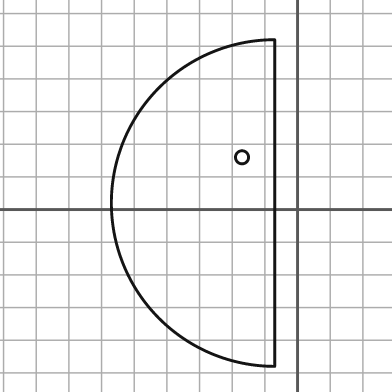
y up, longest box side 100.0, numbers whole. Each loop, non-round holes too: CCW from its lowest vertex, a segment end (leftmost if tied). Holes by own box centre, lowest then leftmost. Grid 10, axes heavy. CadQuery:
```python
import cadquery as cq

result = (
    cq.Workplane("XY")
    .moveTo(-7.0, -48.0)
    .lineTo(-7.0, 52.0)
    .threePointArc((-57.0, 2.0), (-7.0, -48.0))
    .close()
    .moveTo(-17.0, 16.0)
    .circle(2.0)
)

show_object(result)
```